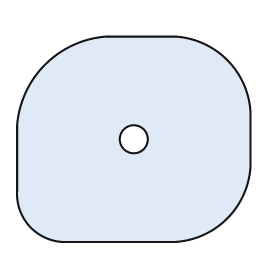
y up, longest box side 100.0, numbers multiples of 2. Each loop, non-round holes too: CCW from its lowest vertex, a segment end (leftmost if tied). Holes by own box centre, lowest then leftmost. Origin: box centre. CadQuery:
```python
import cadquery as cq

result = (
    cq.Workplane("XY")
    .moveTo(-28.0, -44.0)
    .lineTo(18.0, -44.0)
    .threePointArc((40.0, -34.0), (50.0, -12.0))
    .lineTo(50.0, 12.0)
    .threePointArc((40.0, 34.0), (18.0, 44.0))
    .lineTo(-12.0, 44.0)
    .threePointArc((-38.0, 32.0), (-50.0, 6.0))
    .lineTo(-50.0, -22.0)
    .threePointArc((-44.0, -38.0), (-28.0, -44.0))
    .close()
    .moveTo(0.0, 0.0)
    .circle(6.0)
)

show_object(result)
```